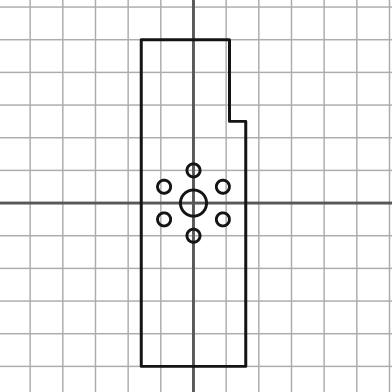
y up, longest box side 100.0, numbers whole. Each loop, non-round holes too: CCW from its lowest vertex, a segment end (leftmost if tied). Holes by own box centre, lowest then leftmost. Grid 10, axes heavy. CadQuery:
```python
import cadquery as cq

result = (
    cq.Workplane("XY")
    .moveTo(-16.0, -50.0)
    .lineTo(16.0, -50.0)
    .lineTo(16.0, 25.0)
    .lineTo(11.0, 25.0)
    .lineTo(11.0, 50.0)
    .lineTo(-16.0, 50.0)
    .close()
    .moveTo(0.0, -10.0)
    .circle(2.0)
    .moveTo(-9.0, -5.0)
    .circle(2.0)
    .moveTo(9.0, -5.0)
    .circle(2.0)
    .moveTo(0.0, 0.0)
    .circle(4.0)
    .moveTo(-9.0, 5.0)
    .circle(2.0)
    .moveTo(9.0, 5.0)
    .circle(2.0)
    .moveTo(0.0, 10.0)
    .circle(2.0)
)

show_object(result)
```